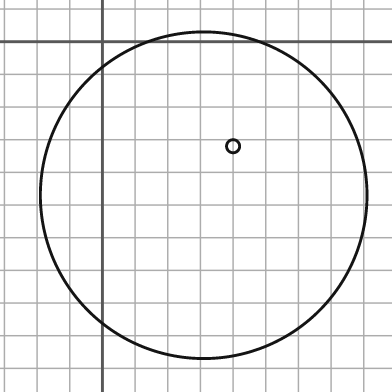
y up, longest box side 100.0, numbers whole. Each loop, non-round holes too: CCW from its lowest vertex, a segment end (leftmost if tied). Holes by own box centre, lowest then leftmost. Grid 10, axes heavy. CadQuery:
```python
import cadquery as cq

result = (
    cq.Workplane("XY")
    .moveTo(31.0, -47.0)
    .circle(50.0)
    .moveTo(40.0, -32.0)
    .circle(2.0)
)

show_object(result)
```